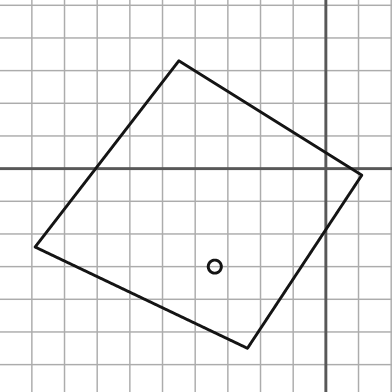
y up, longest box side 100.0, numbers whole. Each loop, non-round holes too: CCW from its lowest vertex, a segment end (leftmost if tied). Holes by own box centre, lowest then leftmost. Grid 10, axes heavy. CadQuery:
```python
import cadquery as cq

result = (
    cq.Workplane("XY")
    .moveTo(-24.0, -55.0)
    .lineTo(11.0, -2.0)
    .lineTo(-45.0, 33.0)
    .lineTo(-89.0, -24.0)
    .close()
    .moveTo(-34.0, -30.0)
    .circle(2.0)
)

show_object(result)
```